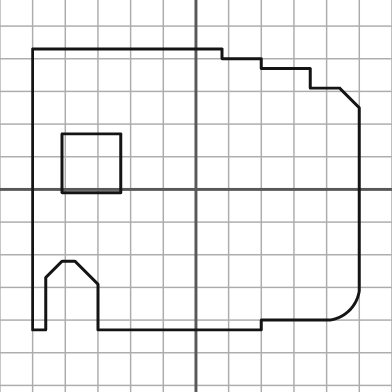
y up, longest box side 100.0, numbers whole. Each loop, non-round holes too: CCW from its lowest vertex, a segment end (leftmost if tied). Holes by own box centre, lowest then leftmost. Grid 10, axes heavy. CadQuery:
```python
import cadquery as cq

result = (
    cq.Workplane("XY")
    .moveTo(-50.0, -43.0)
    .lineTo(-46.0, -43.0)
    .lineTo(-46.0, -27.0)
    .lineTo(-41.0, -22.0)
    .lineTo(-37.0, -22.0)
    .lineTo(-30.0, -29.0)
    .lineTo(-30.0, -43.0)
    .lineTo(20.0, -43.0)
    .lineTo(20.0, -40.0)
    .lineTo(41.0, -40.0)
    .threePointArc((47.0, -37.0), (50.0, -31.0))
    .lineTo(50.0, 25.0)
    .lineTo(44.0, 31.0)
    .lineTo(35.0, 31.0)
    .lineTo(35.0, 37.0)
    .lineTo(20.0, 37.0)
    .lineTo(20.0, 40.0)
    .lineTo(8.0, 40.0)
    .lineTo(8.0, 43.0)
    .lineTo(-50.0, 43.0)
    .close()
    .moveTo(-41.0, -1.0)
    .lineTo(-23.0, -1.0)
    .lineTo(-23.0, 17.0)
    .lineTo(-41.0, 17.0)
    .close()
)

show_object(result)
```